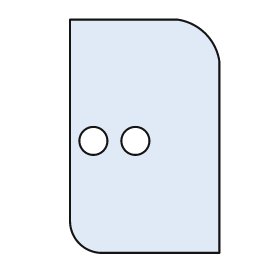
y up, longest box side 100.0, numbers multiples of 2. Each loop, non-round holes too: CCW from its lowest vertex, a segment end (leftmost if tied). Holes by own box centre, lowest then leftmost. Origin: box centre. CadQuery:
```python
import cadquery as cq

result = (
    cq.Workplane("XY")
    .moveTo(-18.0, -50.0)
    .lineTo(32.0, -50.0)
    .lineTo(32.0, 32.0)
    .threePointArc((26.0, 44.0), (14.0, 50.0))
    .lineTo(-32.0, 50.0)
    .lineTo(-32.0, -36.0)
    .threePointArc((-28.0, -46.0), (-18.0, -50.0))
    .close()
    .moveTo(-22.0, -2.0)
    .circle(6.0)
    .moveTo(-4.0, -2.0)
    .circle(6.0)
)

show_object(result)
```